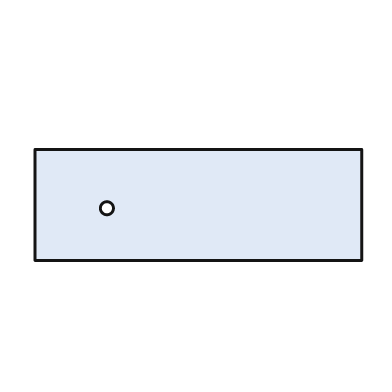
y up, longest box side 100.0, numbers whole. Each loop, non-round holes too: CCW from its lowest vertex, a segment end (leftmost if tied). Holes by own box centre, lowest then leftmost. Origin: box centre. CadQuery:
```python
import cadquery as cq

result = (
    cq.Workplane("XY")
    .moveTo(-50.0, -17.0)
    .lineTo(50.0, -17.0)
    .lineTo(50.0, 17.0)
    .lineTo(-50.0, 17.0)
    .close()
    .moveTo(-28.0, -1.0)
    .circle(2.0)
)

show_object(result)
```